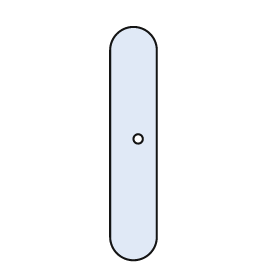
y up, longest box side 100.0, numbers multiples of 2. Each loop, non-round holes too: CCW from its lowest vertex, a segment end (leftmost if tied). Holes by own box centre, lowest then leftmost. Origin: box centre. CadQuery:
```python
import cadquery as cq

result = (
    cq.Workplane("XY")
    .moveTo(-10.0, -40.0)
    .threePointArc((0.0, -50.0), (10.0, -40.0))
    .lineTo(10.0, 40.0)
    .threePointArc((0.0, 50.0), (-10.0, 40.0))
    .close()
    .moveTo(2.0, 2.0)
    .circle(2.0)
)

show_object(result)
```